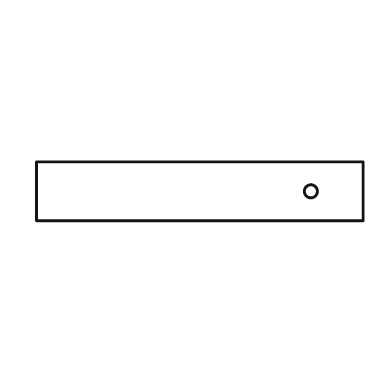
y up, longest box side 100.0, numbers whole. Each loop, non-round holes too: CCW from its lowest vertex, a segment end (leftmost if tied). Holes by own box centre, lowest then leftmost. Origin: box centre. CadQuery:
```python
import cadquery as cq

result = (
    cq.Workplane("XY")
    .moveTo(-50.0, -9.0)
    .lineTo(50.0, -9.0)
    .lineTo(50.0, 9.0)
    .lineTo(-50.0, 9.0)
    .close()
    .moveTo(34.0, 0.0)
    .circle(2.0)
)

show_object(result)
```